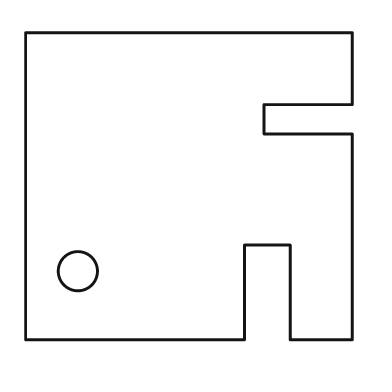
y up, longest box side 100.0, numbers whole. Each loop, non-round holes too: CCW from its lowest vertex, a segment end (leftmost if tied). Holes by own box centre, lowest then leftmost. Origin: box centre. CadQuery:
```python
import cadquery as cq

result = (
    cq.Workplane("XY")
    .moveTo(-50.0, -47.0)
    .lineTo(17.0, -47.0)
    .lineTo(17.0, -18.0)
    .lineTo(31.0, -18.0)
    .lineTo(31.0, -47.0)
    .lineTo(50.0, -47.0)
    .lineTo(50.0, 16.0)
    .lineTo(23.0, 16.0)
    .lineTo(23.0, 25.0)
    .lineTo(50.0, 25.0)
    .lineTo(50.0, 47.0)
    .lineTo(-50.0, 47.0)
    .close()
    .moveTo(-34.0, -26.0)
    .circle(6.0)
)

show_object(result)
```